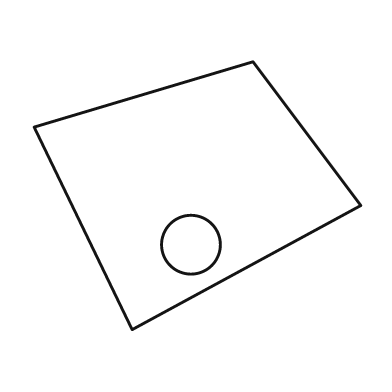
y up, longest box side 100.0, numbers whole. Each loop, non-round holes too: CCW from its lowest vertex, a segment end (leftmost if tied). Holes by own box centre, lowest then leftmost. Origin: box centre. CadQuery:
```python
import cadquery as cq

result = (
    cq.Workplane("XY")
    .moveTo(-20.0, -41.0)
    .lineTo(50.0, -3.0)
    .lineTo(17.0, 41.0)
    .lineTo(-50.0, 21.0)
    .close()
    .moveTo(-2.0, -15.0)
    .circle(9.0)
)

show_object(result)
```